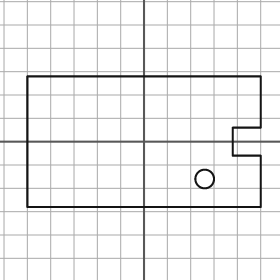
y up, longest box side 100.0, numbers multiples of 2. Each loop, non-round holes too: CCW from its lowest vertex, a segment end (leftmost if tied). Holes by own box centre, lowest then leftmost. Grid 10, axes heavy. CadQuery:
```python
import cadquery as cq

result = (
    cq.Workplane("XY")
    .moveTo(-50.0, -28.0)
    .lineTo(50.0, -28.0)
    .lineTo(50.0, -6.0)
    .lineTo(38.0, -6.0)
    .lineTo(38.0, 6.0)
    .lineTo(50.0, 6.0)
    .lineTo(50.0, 28.0)
    .lineTo(-50.0, 28.0)
    .close()
    .moveTo(26.0, -16.0)
    .circle(4.0)
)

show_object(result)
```